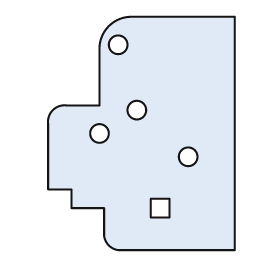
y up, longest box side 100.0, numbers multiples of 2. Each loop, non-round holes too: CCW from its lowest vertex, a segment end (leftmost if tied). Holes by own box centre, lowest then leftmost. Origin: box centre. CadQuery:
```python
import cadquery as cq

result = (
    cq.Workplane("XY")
    .moveTo(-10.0, -50.0)
    .lineTo(40.0, -50.0)
    .lineTo(40.0, 50.0)
    .lineTo(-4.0, 50.0)
    .threePointArc((-14.0, 46.0), (-18.0, 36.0))
    .lineTo(-18.0, 12.0)
    .lineTo(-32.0, 12.0)
    .threePointArc((-38.0, 10.0), (-40.0, 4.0))
    .lineTo(-40.0, -24.0)
    .lineTo(-30.0, -24.0)
    .lineTo(-30.0, -32.0)
    .lineTo(-16.0, -32.0)
    .lineTo(-16.0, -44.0)
    .threePointArc((-14.0, -48.0), (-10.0, -50.0))
    .close()
    .moveTo(4.0, -36.0)
    .lineTo(12.0, -36.0)
    .lineTo(12.0, -28.0)
    .lineTo(4.0, -28.0)
    .close()
    .moveTo(20.0, -10.0)
    .circle(4.0)
    .moveTo(-18.0, 0.0)
    .circle(4.0)
    .moveTo(-2.0, 10.0)
    .circle(4.0)
    .moveTo(-10.0, 38.0)
    .circle(4.0)
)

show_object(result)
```